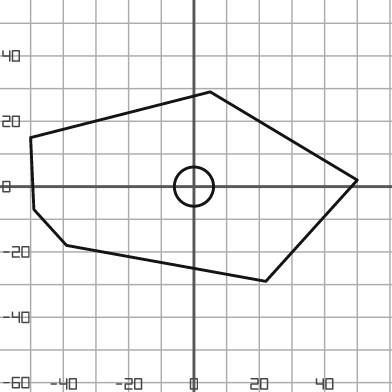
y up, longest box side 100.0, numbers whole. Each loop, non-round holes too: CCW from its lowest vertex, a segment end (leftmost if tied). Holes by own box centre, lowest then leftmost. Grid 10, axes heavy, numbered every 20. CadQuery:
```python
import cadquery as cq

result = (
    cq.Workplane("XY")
    .moveTo(22.0, -29.0)
    .lineTo(50.0, 2.0)
    .lineTo(5.0, 29.0)
    .lineTo(-50.0, 15.0)
    .lineTo(-49.0, -7.0)
    .lineTo(-39.0, -18.0)
    .close()
    .moveTo(0.0, 0.0)
    .circle(6.0)
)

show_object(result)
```